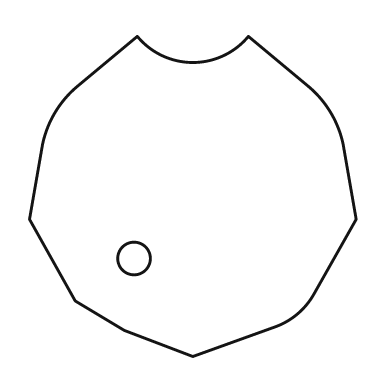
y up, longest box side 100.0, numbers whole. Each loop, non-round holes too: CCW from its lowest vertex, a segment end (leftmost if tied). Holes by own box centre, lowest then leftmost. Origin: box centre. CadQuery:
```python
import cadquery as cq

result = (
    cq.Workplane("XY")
    .moveTo(0.0, -49.0)
    .lineTo(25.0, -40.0)
    .threePointArc((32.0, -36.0), (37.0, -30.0))
    .lineTo(50.0, -7.0)
    .lineTo(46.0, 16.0)
    .threePointArc((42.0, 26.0), (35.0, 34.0))
    .lineTo(17.0, 49.0)
    .threePointArc((0.0, 41.0), (-17.0, 49.0))
    .lineTo(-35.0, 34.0)
    .threePointArc((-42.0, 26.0), (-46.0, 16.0))
    .lineTo(-50.0, -7.0)
    .lineTo(-36.0, -32.0)
    .lineTo(-21.0, -41.0)
    .close()
    .moveTo(-18.0, -19.0)
    .circle(5.0)
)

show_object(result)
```